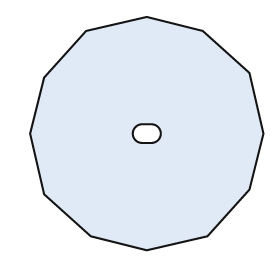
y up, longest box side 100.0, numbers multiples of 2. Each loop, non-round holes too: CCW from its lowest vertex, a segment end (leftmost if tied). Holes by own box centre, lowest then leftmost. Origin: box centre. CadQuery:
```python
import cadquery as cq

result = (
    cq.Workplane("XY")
    .moveTo(0.0, -50.0)
    .lineTo(26.0, -44.0)
    .lineTo(44.0, -24.0)
    .lineTo(50.0, 0.0)
    .lineTo(44.0, 26.0)
    .lineTo(24.0, 44.0)
    .lineTo(0.0, 50.0)
    .lineTo(-26.0, 44.0)
    .lineTo(-44.0, 24.0)
    .lineTo(-50.0, 0.0)
    .lineTo(-44.0, -26.0)
    .lineTo(-24.0, -44.0)
    .close()
    .moveTo(-2.0, -4.0)
    .lineTo(2.0, -4.0)
    .threePointArc((6.0, 0.0), (2.0, 4.0))
    .lineTo(-2.0, 4.0)
    .threePointArc((-6.0, 0.0), (-2.0, -4.0))
    .close()
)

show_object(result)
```